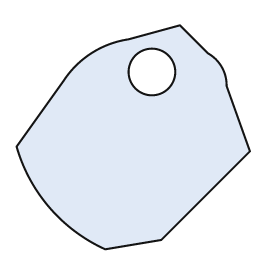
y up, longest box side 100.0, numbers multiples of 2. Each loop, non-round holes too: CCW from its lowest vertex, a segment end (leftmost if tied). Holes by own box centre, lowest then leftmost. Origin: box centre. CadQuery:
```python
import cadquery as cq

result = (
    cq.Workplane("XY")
    .moveTo(-12.0, -48.0)
    .lineTo(12.0, -44.0)
    .lineTo(50.0, -6.0)
    .lineTo(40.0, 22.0)
    .threePointArc((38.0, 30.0), (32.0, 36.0))
    .lineTo(20.0, 48.0)
    .lineTo(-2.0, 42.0)
    .threePointArc((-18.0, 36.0), (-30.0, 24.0))
    .lineTo(-50.0, -4.0)
    .threePointArc((-36.0, -30.0), (-12.0, -48.0))
    .close()
    .moveTo(8.0, 28.0)
    .circle(10.0)
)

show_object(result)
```